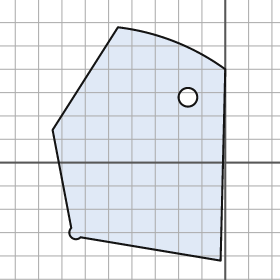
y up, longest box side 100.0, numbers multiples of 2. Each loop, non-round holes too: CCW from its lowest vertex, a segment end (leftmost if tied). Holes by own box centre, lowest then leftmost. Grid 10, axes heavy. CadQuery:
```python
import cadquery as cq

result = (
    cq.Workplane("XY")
    .moveTo(-2.0, -42.0)
    .lineTo(0.0, 40.0)
    .threePointArc((-22.0, 52.0), (-46.0, 58.0))
    .lineTo(-74.0, 14.0)
    .lineTo(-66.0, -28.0)
    .threePointArc((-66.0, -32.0), (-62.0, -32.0))
    .close()
    .moveTo(-16.0, 28.0)
    .circle(4.0)
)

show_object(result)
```